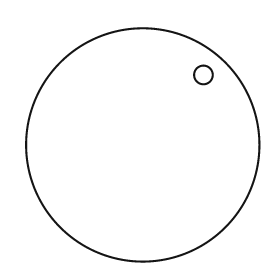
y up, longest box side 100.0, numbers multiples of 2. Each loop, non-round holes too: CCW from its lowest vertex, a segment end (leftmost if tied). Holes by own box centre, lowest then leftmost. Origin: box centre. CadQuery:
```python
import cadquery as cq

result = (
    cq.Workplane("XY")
    .moveTo(0.0, 0.0)
    .circle(50.0)
    .moveTo(26.0, 30.0)
    .circle(4.0)
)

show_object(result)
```